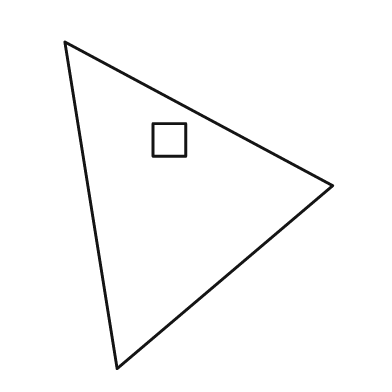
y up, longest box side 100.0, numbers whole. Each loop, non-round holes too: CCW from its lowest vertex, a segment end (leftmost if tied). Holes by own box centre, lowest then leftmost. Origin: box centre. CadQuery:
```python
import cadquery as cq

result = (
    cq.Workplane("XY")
    .moveTo(-25.0, -50.0)
    .lineTo(41.0, 6.0)
    .lineTo(-41.0, 50.0)
    .close()
    .moveTo(-14.0, 15.0)
    .lineTo(-4.0, 15.0)
    .lineTo(-4.0, 25.0)
    .lineTo(-14.0, 25.0)
    .close()
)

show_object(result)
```